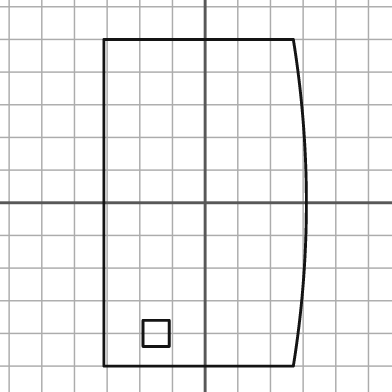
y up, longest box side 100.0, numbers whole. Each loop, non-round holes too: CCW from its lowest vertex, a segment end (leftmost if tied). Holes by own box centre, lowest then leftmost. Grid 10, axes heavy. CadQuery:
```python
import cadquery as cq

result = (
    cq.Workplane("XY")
    .moveTo(-31.0, -50.0)
    .lineTo(27.0, -50.0)
    .threePointArc((31.0, 0.0), (27.0, 50.0))
    .lineTo(-31.0, 50.0)
    .close()
    .moveTo(-19.0, -44.0)
    .lineTo(-11.0, -44.0)
    .lineTo(-11.0, -36.0)
    .lineTo(-19.0, -36.0)
    .close()
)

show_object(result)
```